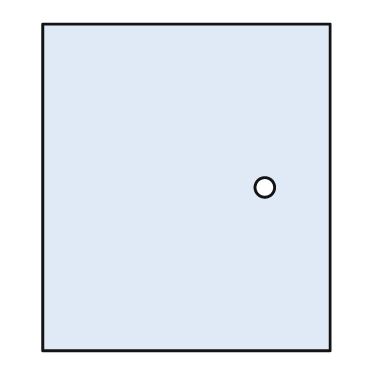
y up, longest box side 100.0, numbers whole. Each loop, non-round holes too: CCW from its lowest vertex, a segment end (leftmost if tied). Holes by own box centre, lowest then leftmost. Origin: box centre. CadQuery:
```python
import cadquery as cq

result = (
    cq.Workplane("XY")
    .moveTo(-44.0, -50.0)
    .lineTo(44.0, -50.0)
    .lineTo(44.0, 50.0)
    .lineTo(-44.0, 50.0)
    .close()
    .moveTo(24.0, 0.0)
    .circle(3.0)
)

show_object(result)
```